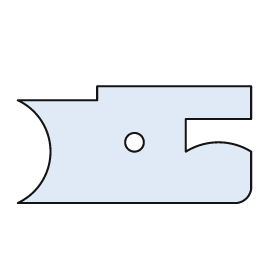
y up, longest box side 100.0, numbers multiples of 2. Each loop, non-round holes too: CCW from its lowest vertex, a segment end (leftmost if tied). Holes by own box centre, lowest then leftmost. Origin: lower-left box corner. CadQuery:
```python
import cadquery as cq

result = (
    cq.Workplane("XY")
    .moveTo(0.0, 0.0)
    .lineTo(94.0, 0.0)
    .threePointArc((98.0, 2.0), (100.0, 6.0))
    .lineTo(100.0, 22.0)
    .threePointArc((86.0, 26.0), (72.0, 22.0))
    .lineTo(72.0, 36.0)
    .lineTo(100.0, 36.0)
    .lineTo(100.0, 50.0)
    .lineTo(34.0, 50.0)
    .lineTo(34.0, 44.0)
    .lineTo(0.0, 44.0)
    .threePointArc((14.0, 22.0), (0.0, 0.0))
    .close()
    .moveTo(50.0, 26.0)
    .circle(4.0)
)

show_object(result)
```